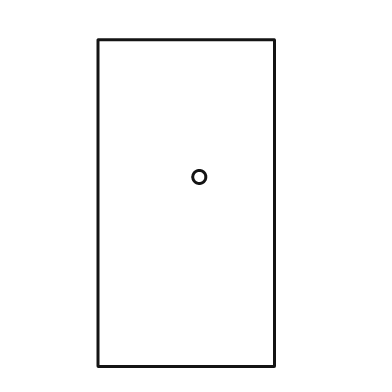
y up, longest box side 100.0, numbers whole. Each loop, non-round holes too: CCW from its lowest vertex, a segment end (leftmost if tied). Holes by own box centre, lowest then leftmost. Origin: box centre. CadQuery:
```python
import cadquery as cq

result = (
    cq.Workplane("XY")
    .moveTo(-27.0, -50.0)
    .lineTo(27.0, -50.0)
    .lineTo(27.0, 50.0)
    .lineTo(-27.0, 50.0)
    .close()
    .moveTo(4.0, 8.0)
    .circle(2.0)
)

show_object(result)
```